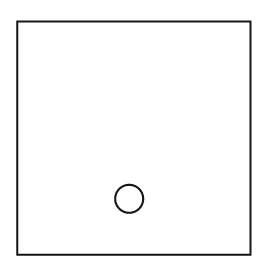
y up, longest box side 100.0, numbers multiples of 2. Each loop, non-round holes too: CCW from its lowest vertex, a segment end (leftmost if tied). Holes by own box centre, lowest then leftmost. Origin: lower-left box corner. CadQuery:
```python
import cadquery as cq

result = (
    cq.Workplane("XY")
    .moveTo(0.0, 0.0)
    .lineTo(100.0, 0.0)
    .lineTo(100.0, 100.0)
    .lineTo(0.0, 100.0)
    .close()
    .moveTo(48.0, 24.0)
    .circle(6.0)
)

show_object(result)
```